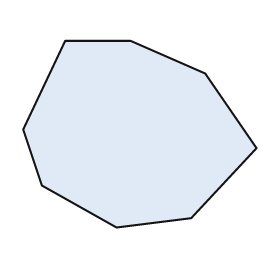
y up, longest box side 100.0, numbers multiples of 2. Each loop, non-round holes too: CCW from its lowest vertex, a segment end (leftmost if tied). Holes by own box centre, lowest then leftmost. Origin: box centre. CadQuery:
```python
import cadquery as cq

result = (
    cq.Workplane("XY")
    .moveTo(-10.0, -40.0)
    .lineTo(22.0, -36.0)
    .lineTo(50.0, -6.0)
    .lineTo(28.0, 26.0)
    .lineTo(-4.0, 40.0)
    .lineTo(-32.0, 40.0)
    .lineTo(-50.0, 2.0)
    .lineTo(-42.0, -22.0)
    .close()
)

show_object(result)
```